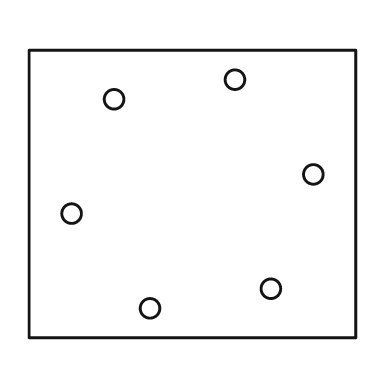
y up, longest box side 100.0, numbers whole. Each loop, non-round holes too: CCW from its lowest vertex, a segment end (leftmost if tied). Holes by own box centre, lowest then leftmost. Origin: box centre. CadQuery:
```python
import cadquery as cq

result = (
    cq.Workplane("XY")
    .moveTo(-50.0, -44.0)
    .lineTo(50.0, -44.0)
    .lineTo(50.0, 44.0)
    .lineTo(-50.0, 44.0)
    .close()
    .moveTo(-13.0, -35.0)
    .circle(3.0)
    .moveTo(24.0, -29.0)
    .circle(3.0)
    .moveTo(-37.0, -6.0)
    .circle(3.0)
    .moveTo(37.0, 6.0)
    .circle(3.0)
    .moveTo(-24.0, 29.0)
    .circle(3.0)
    .moveTo(13.0, 35.0)
    .circle(3.0)
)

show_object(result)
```